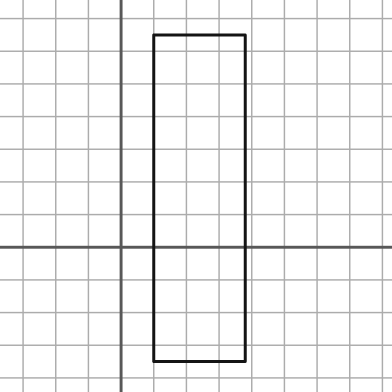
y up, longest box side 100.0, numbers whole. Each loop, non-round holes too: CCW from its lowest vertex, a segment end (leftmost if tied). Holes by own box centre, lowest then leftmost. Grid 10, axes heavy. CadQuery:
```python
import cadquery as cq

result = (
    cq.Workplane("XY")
    .moveTo(10.0, -35.0)
    .lineTo(38.0, -35.0)
    .lineTo(38.0, 65.0)
    .lineTo(10.0, 65.0)
    .close()
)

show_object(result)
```